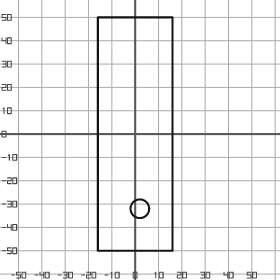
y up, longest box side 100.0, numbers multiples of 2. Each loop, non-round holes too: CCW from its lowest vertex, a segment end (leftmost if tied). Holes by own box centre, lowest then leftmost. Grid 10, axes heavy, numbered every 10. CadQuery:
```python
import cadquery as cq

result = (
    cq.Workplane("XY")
    .moveTo(-16.0, -50.0)
    .lineTo(16.0, -50.0)
    .lineTo(16.0, 50.0)
    .lineTo(-16.0, 50.0)
    .close()
    .moveTo(2.0, -32.0)
    .circle(4.0)
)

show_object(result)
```